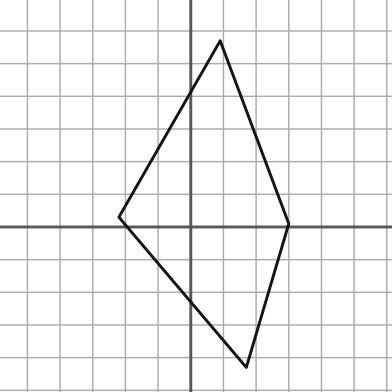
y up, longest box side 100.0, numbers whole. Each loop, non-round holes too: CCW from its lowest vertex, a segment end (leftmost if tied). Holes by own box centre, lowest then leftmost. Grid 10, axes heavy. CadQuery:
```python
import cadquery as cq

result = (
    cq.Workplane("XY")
    .moveTo(17.0, -43.0)
    .lineTo(30.0, 1.0)
    .lineTo(9.0, 57.0)
    .lineTo(-22.0, 3.0)
    .close()
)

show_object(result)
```